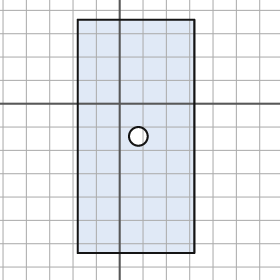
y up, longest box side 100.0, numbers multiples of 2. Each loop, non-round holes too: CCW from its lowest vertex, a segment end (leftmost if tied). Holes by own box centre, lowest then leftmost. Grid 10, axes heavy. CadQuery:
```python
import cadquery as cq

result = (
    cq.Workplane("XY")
    .moveTo(-18.0, -64.0)
    .lineTo(32.0, -64.0)
    .lineTo(32.0, 36.0)
    .lineTo(-18.0, 36.0)
    .close()
    .moveTo(8.0, -14.0)
    .circle(4.0)
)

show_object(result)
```